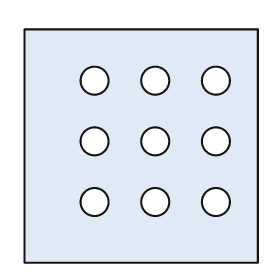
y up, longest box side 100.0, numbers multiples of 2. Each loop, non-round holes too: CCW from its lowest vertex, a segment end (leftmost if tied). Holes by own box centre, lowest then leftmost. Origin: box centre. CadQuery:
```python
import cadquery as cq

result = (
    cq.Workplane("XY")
    .moveTo(-50.0, -50.0)
    .lineTo(50.0, -50.0)
    .lineTo(50.0, 50.0)
    .lineTo(-50.0, 50.0)
    .close()
    .moveTo(-20.0, -24.0)
    .circle(6.0)
    .moveTo(6.0, -24.0)
    .circle(6.0)
    .moveTo(32.0, -24.0)
    .circle(6.0)
    .moveTo(-20.0, 2.0)
    .circle(6.0)
    .moveTo(6.0, 2.0)
    .circle(6.0)
    .moveTo(32.0, 2.0)
    .circle(6.0)
    .moveTo(-20.0, 28.0)
    .circle(6.0)
    .moveTo(6.0, 28.0)
    .circle(6.0)
    .moveTo(32.0, 28.0)
    .circle(6.0)
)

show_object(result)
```